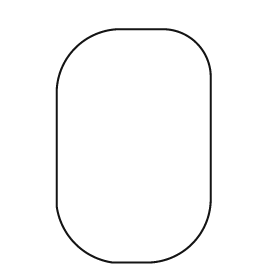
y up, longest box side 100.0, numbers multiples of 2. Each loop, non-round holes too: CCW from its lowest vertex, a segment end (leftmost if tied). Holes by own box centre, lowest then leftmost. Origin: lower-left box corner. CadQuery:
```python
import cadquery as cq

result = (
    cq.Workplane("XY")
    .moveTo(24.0, 0.0)
    .lineTo(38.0, 0.0)
    .threePointArc((58.0, 8.0), (66.0, 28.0))
    .lineTo(66.0, 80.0)
    .threePointArc((60.0, 94.0), (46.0, 100.0))
    .lineTo(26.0, 100.0)
    .threePointArc((8.0, 92.0), (0.0, 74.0))
    .lineTo(0.0, 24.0)
    .threePointArc((8.0, 8.0), (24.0, 0.0))
    .close()
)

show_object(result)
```